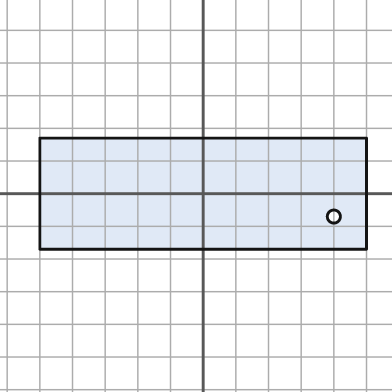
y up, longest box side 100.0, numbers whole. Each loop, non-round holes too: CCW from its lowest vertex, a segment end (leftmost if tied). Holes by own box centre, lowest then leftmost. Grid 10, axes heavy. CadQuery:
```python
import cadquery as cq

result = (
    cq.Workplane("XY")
    .moveTo(-50.0, -17.0)
    .lineTo(50.0, -17.0)
    .lineTo(50.0, 17.0)
    .lineTo(-50.0, 17.0)
    .close()
    .moveTo(40.0, -7.0)
    .circle(2.0)
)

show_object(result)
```